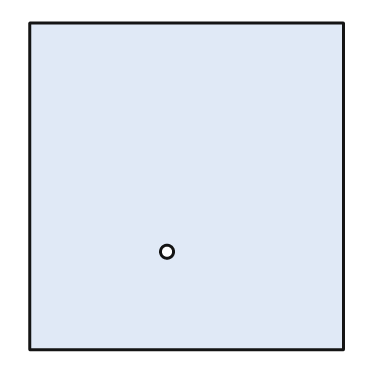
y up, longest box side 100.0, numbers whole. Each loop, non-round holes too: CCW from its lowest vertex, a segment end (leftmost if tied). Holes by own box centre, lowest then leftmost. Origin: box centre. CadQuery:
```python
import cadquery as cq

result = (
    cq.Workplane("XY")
    .moveTo(-48.0, -50.0)
    .lineTo(48.0, -50.0)
    .lineTo(48.0, 50.0)
    .lineTo(-48.0, 50.0)
    .close()
    .moveTo(-6.0, -20.0)
    .circle(2.0)
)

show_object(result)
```